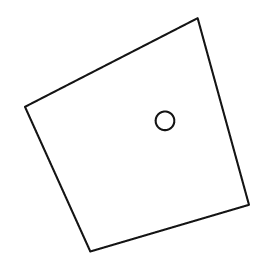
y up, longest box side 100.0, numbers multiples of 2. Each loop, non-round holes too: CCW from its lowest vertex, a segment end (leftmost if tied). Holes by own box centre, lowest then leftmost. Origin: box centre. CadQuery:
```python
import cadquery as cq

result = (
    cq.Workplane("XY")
    .moveTo(-20.0, -50.0)
    .lineTo(48.0, -30.0)
    .lineTo(26.0, 50.0)
    .lineTo(-48.0, 12.0)
    .close()
    .moveTo(12.0, 6.0)
    .circle(4.0)
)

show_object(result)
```